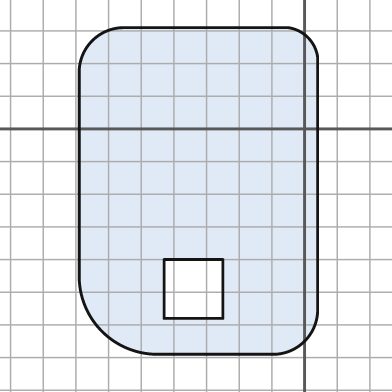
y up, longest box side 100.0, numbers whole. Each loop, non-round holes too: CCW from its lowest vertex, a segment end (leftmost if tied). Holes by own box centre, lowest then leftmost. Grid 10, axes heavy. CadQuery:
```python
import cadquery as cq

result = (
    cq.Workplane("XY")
    .moveTo(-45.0, -69.0)
    .lineTo(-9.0, -69.0)
    .threePointArc((0.0, -65.0), (4.0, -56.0))
    .lineTo(4.0, 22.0)
    .threePointArc((1.0, 28.0), (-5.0, 31.0))
    .lineTo(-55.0, 31.0)
    .threePointArc((-65.0, 27.0), (-69.0, 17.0))
    .lineTo(-69.0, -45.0)
    .threePointArc((-62.0, -62.0), (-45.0, -69.0))
    .close()
    .moveTo(-43.0, -58.0)
    .lineTo(-25.0, -58.0)
    .lineTo(-25.0, -40.0)
    .lineTo(-43.0, -40.0)
    .close()
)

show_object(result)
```